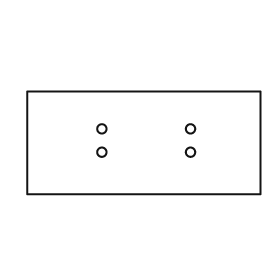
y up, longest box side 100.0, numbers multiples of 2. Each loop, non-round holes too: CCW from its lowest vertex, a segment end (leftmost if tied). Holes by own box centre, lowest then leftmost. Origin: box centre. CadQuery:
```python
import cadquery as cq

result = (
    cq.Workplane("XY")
    .moveTo(-50.0, -22.0)
    .lineTo(50.0, -22.0)
    .lineTo(50.0, 22.0)
    .lineTo(-50.0, 22.0)
    .close()
    .moveTo(-18.0, -4.0)
    .circle(2.0)
    .moveTo(20.0, -4.0)
    .circle(2.0)
    .moveTo(-18.0, 6.0)
    .circle(2.0)
    .moveTo(20.0, 6.0)
    .circle(2.0)
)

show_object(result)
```